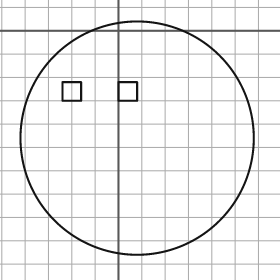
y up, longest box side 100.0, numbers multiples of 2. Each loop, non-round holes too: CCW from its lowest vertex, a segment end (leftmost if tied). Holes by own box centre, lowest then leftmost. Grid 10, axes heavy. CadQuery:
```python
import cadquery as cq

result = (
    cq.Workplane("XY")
    .moveTo(8.0, -46.0)
    .circle(50.0)
    .moveTo(-24.0, -30.0)
    .lineTo(-16.0, -30.0)
    .lineTo(-16.0, -22.0)
    .lineTo(-24.0, -22.0)
    .close()
    .moveTo(0.0, -30.0)
    .lineTo(8.0, -30.0)
    .lineTo(8.0, -22.0)
    .lineTo(0.0, -22.0)
    .close()
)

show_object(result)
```